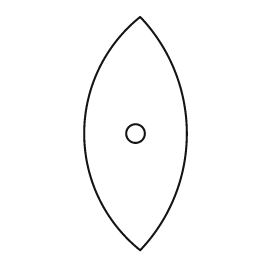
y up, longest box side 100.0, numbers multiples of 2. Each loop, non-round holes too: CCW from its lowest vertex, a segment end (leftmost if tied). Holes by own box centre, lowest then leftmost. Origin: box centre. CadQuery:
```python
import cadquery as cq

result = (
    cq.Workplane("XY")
    .moveTo(2.0, -50.0)
    .threePointArc((22.0, 0.0), (2.0, 50.0))
    .threePointArc((-22.0, 0.0), (2.0, -50.0))
    .close()
    .moveTo(0.0, 0.0)
    .circle(4.0)
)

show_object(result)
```